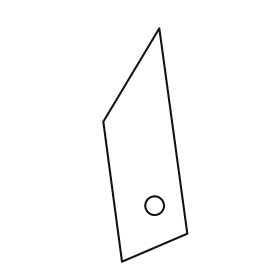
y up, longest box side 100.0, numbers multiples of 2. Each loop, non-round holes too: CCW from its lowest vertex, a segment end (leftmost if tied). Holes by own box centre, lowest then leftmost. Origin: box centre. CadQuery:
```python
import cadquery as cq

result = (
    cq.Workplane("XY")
    .moveTo(-10.0, -50.0)
    .lineTo(18.0, -38.0)
    .lineTo(6.0, 50.0)
    .lineTo(-18.0, 10.0)
    .close()
    .moveTo(4.0, -26.0)
    .circle(4.0)
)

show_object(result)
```